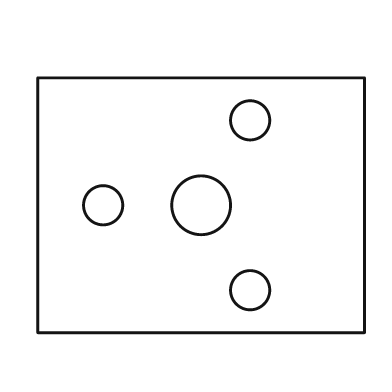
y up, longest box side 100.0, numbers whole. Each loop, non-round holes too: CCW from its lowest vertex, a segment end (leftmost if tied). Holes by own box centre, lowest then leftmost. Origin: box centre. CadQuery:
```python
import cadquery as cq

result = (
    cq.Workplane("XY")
    .moveTo(-50.0, -39.0)
    .lineTo(50.0, -39.0)
    .lineTo(50.0, 39.0)
    .lineTo(-50.0, 39.0)
    .close()
    .moveTo(15.0, -26.0)
    .circle(6.0)
    .moveTo(-30.0, 0.0)
    .circle(6.0)
    .moveTo(0.0, 0.0)
    .circle(9.0)
    .moveTo(15.0, 26.0)
    .circle(6.0)
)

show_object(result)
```